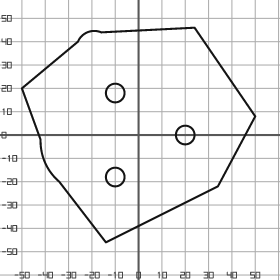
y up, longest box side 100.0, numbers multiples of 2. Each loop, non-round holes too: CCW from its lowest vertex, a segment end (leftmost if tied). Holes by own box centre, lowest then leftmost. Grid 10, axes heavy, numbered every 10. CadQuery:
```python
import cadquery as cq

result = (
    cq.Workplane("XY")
    .moveTo(-14.0, -46.0)
    .lineTo(34.0, -22.0)
    .lineTo(50.0, 8.0)
    .lineTo(24.0, 46.0)
    .lineTo(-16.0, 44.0)
    .threePointArc((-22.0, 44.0), (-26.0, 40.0))
    .lineTo(-50.0, 20.0)
    .lineTo(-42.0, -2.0)
    .threePointArc((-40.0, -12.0), (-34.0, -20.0))
    .close()
    .moveTo(-10.0, -18.0)
    .circle(4.0)
    .moveTo(20.0, 0.0)
    .circle(4.0)
    .moveTo(-10.0, 18.0)
    .circle(4.0)
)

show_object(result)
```